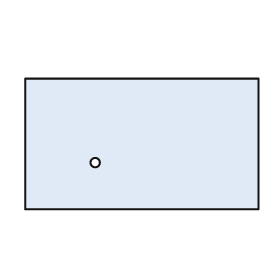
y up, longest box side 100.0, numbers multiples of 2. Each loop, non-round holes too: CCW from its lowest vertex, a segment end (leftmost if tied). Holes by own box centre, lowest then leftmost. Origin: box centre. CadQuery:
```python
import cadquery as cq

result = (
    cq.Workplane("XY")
    .moveTo(-50.0, -28.0)
    .lineTo(50.0, -28.0)
    .lineTo(50.0, 28.0)
    .lineTo(-50.0, 28.0)
    .close()
    .moveTo(-20.0, -8.0)
    .circle(2.0)
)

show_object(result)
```